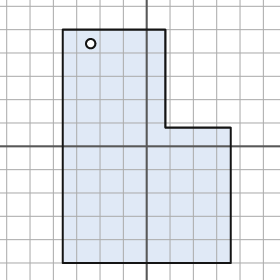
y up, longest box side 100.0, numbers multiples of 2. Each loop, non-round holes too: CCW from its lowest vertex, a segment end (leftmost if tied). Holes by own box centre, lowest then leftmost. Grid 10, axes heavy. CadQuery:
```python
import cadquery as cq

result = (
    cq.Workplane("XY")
    .moveTo(-36.0, -50.0)
    .lineTo(36.0, -50.0)
    .lineTo(36.0, 8.0)
    .lineTo(8.0, 8.0)
    .lineTo(8.0, 50.0)
    .lineTo(-36.0, 50.0)
    .close()
    .moveTo(-24.0, 44.0)
    .circle(2.0)
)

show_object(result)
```